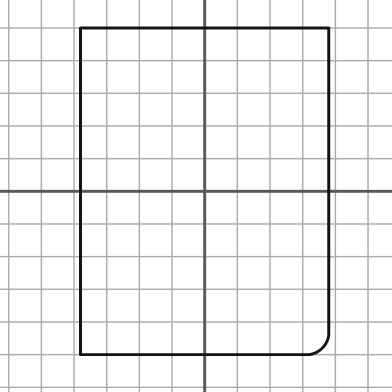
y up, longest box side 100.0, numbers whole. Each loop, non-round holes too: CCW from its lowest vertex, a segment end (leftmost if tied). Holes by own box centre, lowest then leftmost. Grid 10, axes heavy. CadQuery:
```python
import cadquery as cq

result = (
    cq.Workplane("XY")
    .moveTo(-38.0, -50.0)
    .lineTo(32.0, -50.0)
    .threePointArc((36.0, -48.0), (38.0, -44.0))
    .lineTo(38.0, 50.0)
    .lineTo(-38.0, 50.0)
    .close()
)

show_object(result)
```